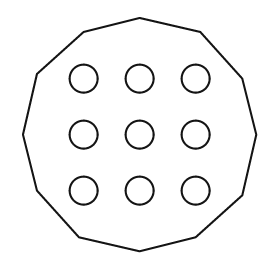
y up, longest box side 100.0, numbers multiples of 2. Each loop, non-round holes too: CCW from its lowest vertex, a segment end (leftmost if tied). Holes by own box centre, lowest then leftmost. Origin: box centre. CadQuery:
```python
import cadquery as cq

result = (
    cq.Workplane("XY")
    .moveTo(0.0, -50.0)
    .lineTo(24.0, -44.0)
    .lineTo(44.0, -26.0)
    .lineTo(50.0, 0.0)
    .lineTo(44.0, 24.0)
    .lineTo(26.0, 44.0)
    .lineTo(0.0, 50.0)
    .lineTo(-24.0, 44.0)
    .lineTo(-44.0, 26.0)
    .lineTo(-50.0, 0.0)
    .lineTo(-44.0, -24.0)
    .lineTo(-26.0, -44.0)
    .close()
    .moveTo(-24.0, -24.0)
    .circle(6.0)
    .moveTo(0.0, -24.0)
    .circle(6.0)
    .moveTo(24.0, -24.0)
    .circle(6.0)
    .moveTo(-24.0, 0.0)
    .circle(6.0)
    .moveTo(0.0, 0.0)
    .circle(6.0)
    .moveTo(24.0, 0.0)
    .circle(6.0)
    .moveTo(-24.0, 24.0)
    .circle(6.0)
    .moveTo(0.0, 24.0)
    .circle(6.0)
    .moveTo(24.0, 24.0)
    .circle(6.0)
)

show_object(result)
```